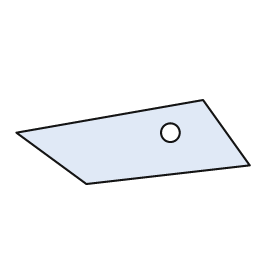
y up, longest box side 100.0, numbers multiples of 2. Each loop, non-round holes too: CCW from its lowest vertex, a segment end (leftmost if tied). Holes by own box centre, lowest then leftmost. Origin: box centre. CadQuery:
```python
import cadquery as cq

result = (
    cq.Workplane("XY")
    .moveTo(-20.0, -18.0)
    .lineTo(50.0, -10.0)
    .lineTo(30.0, 18.0)
    .lineTo(-50.0, 4.0)
    .close()
    .moveTo(16.0, 4.0)
    .circle(4.0)
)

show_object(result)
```